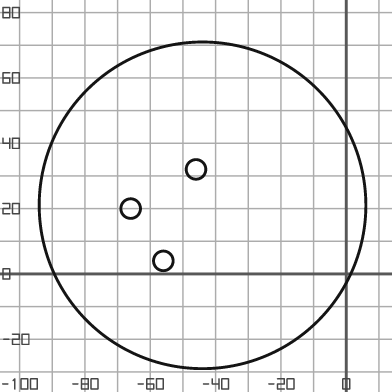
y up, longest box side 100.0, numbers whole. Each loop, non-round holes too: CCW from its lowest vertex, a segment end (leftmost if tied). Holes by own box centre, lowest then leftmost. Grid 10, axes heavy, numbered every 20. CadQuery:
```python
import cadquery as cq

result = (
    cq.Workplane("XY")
    .moveTo(-44.0, 21.0)
    .circle(50.0)
    .moveTo(-56.0, 4.0)
    .circle(3.0)
    .moveTo(-66.0, 20.0)
    .circle(3.0)
    .moveTo(-46.0, 32.0)
    .circle(3.0)
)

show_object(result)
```